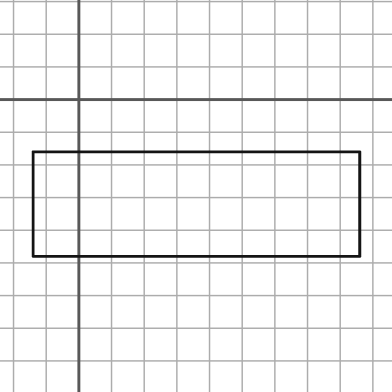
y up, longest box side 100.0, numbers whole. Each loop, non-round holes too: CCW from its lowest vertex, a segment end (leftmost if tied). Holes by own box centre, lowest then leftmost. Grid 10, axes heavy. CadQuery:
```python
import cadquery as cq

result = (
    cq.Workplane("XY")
    .moveTo(-14.0, -48.0)
    .lineTo(86.0, -48.0)
    .lineTo(86.0, -16.0)
    .lineTo(-14.0, -16.0)
    .close()
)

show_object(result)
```